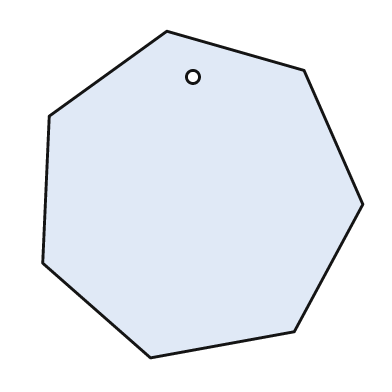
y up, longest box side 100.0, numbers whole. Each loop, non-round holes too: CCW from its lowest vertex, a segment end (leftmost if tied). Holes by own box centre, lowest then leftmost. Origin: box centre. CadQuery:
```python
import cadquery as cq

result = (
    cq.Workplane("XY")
    .moveTo(-16.0, -50.0)
    .lineTo(28.0, -42.0)
    .lineTo(49.0, -3.0)
    .lineTo(31.0, 38.0)
    .lineTo(-11.0, 50.0)
    .lineTo(-47.0, 24.0)
    .lineTo(-49.0, -21.0)
    .close()
    .moveTo(-3.0, 36.0)
    .circle(2.0)
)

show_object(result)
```